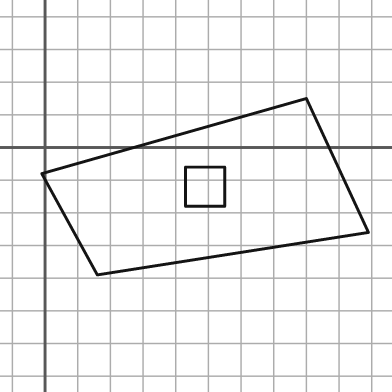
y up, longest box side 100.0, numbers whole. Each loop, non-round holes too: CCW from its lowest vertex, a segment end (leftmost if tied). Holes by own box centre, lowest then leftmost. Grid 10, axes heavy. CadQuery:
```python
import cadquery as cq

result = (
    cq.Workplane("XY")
    .moveTo(16.0, -39.0)
    .lineTo(99.0, -26.0)
    .lineTo(80.0, 15.0)
    .lineTo(-1.0, -8.0)
    .close()
    .moveTo(43.0, -18.0)
    .lineTo(55.0, -18.0)
    .lineTo(55.0, -6.0)
    .lineTo(43.0, -6.0)
    .close()
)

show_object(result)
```